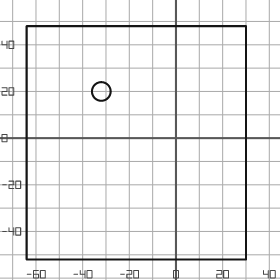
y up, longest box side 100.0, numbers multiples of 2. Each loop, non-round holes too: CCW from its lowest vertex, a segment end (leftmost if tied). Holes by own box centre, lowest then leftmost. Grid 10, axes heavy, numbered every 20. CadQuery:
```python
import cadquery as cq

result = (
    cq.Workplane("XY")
    .moveTo(-64.0, -52.0)
    .lineTo(30.0, -52.0)
    .lineTo(30.0, 48.0)
    .lineTo(-64.0, 48.0)
    .close()
    .moveTo(-32.0, 20.0)
    .circle(4.0)
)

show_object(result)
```